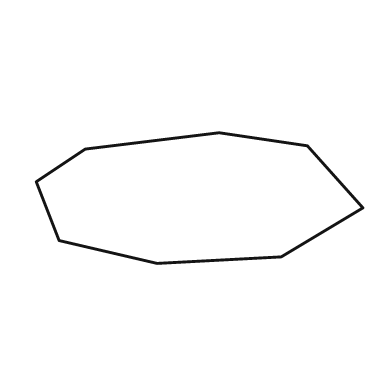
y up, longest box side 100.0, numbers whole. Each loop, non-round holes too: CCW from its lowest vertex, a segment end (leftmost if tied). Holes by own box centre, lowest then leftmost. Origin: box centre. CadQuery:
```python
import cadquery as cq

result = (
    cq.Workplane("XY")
    .moveTo(-13.0, -20.0)
    .lineTo(25.0, -18.0)
    .lineTo(50.0, -3.0)
    .lineTo(33.0, 16.0)
    .lineTo(6.0, 20.0)
    .lineTo(-35.0, 15.0)
    .lineTo(-50.0, 5.0)
    .lineTo(-43.0, -13.0)
    .close()
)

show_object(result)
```